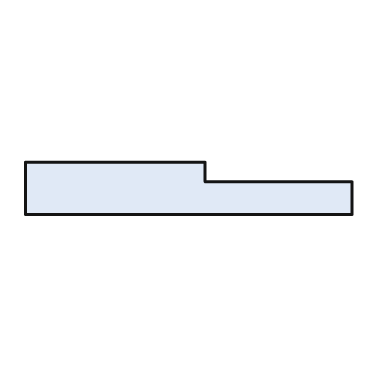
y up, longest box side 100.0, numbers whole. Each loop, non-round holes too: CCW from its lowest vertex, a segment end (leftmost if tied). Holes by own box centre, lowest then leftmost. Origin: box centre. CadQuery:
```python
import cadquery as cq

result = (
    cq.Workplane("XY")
    .moveTo(-50.0, -8.0)
    .lineTo(50.0, -8.0)
    .lineTo(50.0, 2.0)
    .lineTo(5.0, 2.0)
    .lineTo(5.0, 8.0)
    .lineTo(-50.0, 8.0)
    .close()
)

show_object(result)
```